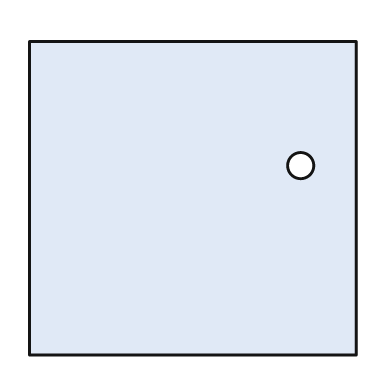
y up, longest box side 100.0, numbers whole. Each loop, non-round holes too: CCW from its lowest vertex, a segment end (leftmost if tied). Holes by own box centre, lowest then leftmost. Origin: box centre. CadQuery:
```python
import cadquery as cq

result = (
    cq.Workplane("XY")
    .moveTo(-50.0, -48.0)
    .lineTo(50.0, -48.0)
    .lineTo(50.0, 48.0)
    .lineTo(-50.0, 48.0)
    .close()
    .moveTo(33.0, 10.0)
    .circle(4.0)
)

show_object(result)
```